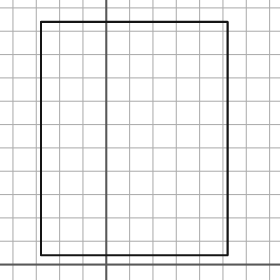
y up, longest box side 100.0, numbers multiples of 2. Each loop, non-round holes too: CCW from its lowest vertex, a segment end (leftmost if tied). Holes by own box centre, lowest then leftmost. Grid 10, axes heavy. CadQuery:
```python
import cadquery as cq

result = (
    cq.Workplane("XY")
    .moveTo(-28.0, 4.0)
    .lineTo(52.0, 4.0)
    .lineTo(52.0, 104.0)
    .lineTo(-28.0, 104.0)
    .close()
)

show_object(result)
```